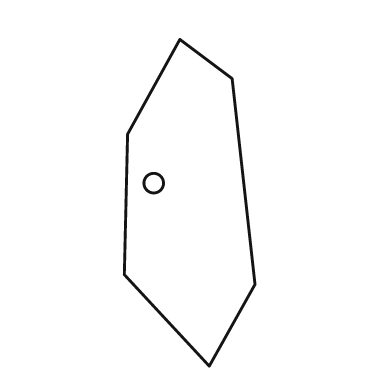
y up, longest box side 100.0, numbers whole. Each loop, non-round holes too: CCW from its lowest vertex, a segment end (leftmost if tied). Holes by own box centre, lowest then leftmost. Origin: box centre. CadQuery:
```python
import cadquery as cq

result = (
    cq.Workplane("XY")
    .moveTo(6.0, -50.0)
    .lineTo(20.0, -25.0)
    .lineTo(13.0, 38.0)
    .lineTo(-3.0, 50.0)
    .lineTo(-19.0, 21.0)
    .lineTo(-20.0, -22.0)
    .close()
    .moveTo(-11.0, 6.0)
    .circle(3.0)
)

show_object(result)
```